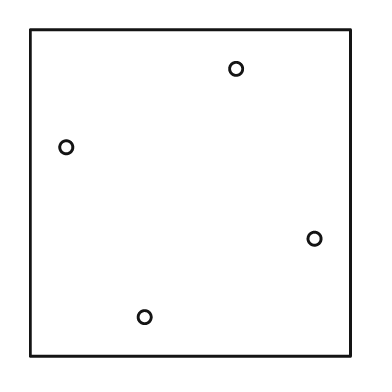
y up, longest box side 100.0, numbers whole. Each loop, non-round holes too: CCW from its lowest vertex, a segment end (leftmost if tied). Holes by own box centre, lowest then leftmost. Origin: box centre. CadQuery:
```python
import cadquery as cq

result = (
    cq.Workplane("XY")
    .moveTo(-49.0, -50.0)
    .lineTo(49.0, -50.0)
    .lineTo(49.0, 50.0)
    .lineTo(-49.0, 50.0)
    .close()
    .moveTo(-14.0, -38.0)
    .circle(2.0)
    .moveTo(38.0, -14.0)
    .circle(2.0)
    .moveTo(-38.0, 14.0)
    .circle(2.0)
    .moveTo(14.0, 38.0)
    .circle(2.0)
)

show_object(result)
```